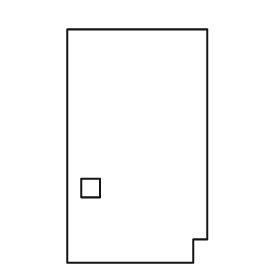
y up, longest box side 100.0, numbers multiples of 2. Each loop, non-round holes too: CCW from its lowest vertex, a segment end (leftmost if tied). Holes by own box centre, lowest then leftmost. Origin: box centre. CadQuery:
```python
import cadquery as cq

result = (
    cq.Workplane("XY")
    .moveTo(-30.0, -50.0)
    .lineTo(24.0, -50.0)
    .lineTo(24.0, -40.0)
    .lineTo(30.0, -40.0)
    .lineTo(30.0, 50.0)
    .lineTo(-30.0, 50.0)
    .close()
    .moveTo(-24.0, -22.0)
    .lineTo(-16.0, -22.0)
    .lineTo(-16.0, -14.0)
    .lineTo(-24.0, -14.0)
    .close()
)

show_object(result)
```